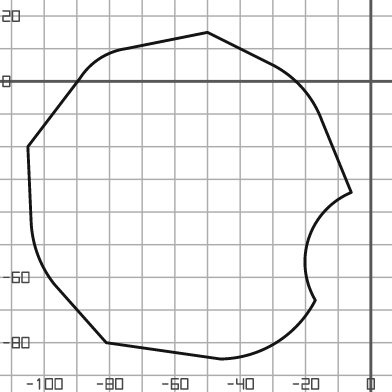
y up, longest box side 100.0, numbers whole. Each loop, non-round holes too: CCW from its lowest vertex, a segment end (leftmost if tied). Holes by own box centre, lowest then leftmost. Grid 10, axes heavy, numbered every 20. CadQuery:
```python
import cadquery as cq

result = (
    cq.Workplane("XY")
    .moveTo(-46.0, -85.0)
    .threePointArc((-29.0, -80.0), (-17.0, -67.0))
    .threePointArc((-19.0, -48.0), (-6.0, -34.0))
    .lineTo(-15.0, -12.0)
    .threePointArc((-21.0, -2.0), (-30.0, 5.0))
    .lineTo(-50.0, 15.0)
    .lineTo(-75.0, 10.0)
    .threePointArc((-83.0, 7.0), (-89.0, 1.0))
    .lineTo(-105.0, -20.0)
    .lineTo(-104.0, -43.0)
    .threePointArc((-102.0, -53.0), (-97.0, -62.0))
    .lineTo(-81.0, -80.0)
    .close()
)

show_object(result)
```